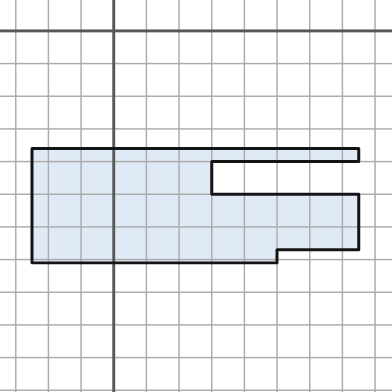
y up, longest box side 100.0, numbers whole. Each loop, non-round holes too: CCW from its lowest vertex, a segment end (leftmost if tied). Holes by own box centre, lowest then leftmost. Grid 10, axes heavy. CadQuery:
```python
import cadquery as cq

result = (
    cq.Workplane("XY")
    .moveTo(-25.0, -71.0)
    .lineTo(50.0, -71.0)
    .lineTo(50.0, -67.0)
    .lineTo(75.0, -67.0)
    .lineTo(75.0, -50.0)
    .lineTo(30.0, -50.0)
    .lineTo(30.0, -40.0)
    .lineTo(75.0, -40.0)
    .lineTo(75.0, -36.0)
    .lineTo(-25.0, -36.0)
    .close()
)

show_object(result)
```